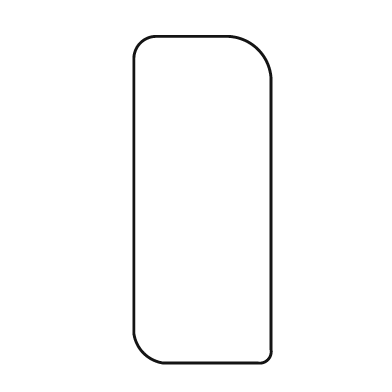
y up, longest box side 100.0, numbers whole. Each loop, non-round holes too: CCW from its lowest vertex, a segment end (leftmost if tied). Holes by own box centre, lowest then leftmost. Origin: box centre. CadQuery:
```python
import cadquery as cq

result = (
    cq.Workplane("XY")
    .moveTo(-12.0, -50.0)
    .lineTo(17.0, -50.0)
    .threePointArc((20.0, -49.0), (21.0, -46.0))
    .lineTo(21.0, 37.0)
    .threePointArc((17.0, 46.0), (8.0, 50.0))
    .lineTo(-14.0, 50.0)
    .threePointArc((-19.0, 48.0), (-21.0, 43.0))
    .lineTo(-21.0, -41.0)
    .threePointArc((-18.0, -47.0), (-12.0, -50.0))
    .close()
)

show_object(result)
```